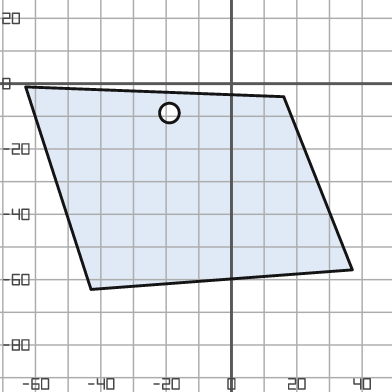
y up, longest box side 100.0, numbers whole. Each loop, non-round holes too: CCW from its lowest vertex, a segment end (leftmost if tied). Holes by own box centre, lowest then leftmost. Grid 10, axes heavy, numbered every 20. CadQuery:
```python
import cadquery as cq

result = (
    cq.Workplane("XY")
    .moveTo(-43.0, -63.0)
    .lineTo(37.0, -57.0)
    .lineTo(16.0, -4.0)
    .lineTo(-63.0, -1.0)
    .close()
    .moveTo(-19.0, -9.0)
    .circle(3.0)
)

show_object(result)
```